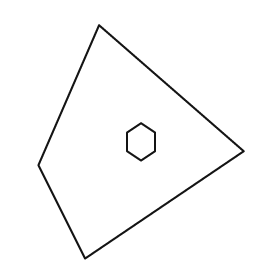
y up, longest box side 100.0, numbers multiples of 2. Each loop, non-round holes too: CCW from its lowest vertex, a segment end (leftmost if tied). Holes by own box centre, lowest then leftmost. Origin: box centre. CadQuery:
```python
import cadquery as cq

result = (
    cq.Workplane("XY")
    .moveTo(-24.0, -50.0)
    .lineTo(44.0, -4.0)
    .lineTo(-18.0, 50.0)
    .lineTo(-44.0, -10.0)
    .close()
    .moveTo(0.0, -8.0)
    .lineTo(6.0, -4.0)
    .lineTo(6.0, 4.0)
    .lineTo(0.0, 8.0)
    .lineTo(-6.0, 4.0)
    .lineTo(-6.0, -4.0)
    .close()
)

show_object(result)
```